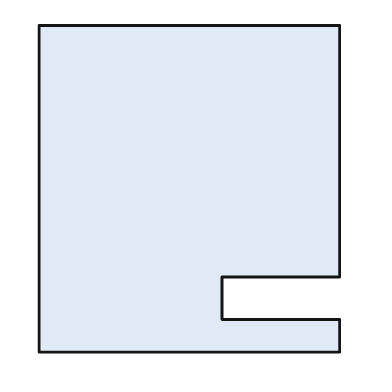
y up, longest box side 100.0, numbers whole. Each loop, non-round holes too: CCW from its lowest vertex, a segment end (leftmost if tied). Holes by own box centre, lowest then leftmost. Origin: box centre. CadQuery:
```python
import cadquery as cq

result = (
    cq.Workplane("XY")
    .moveTo(-46.0, -50.0)
    .lineTo(46.0, -50.0)
    .lineTo(46.0, -40.0)
    .lineTo(10.0, -40.0)
    .lineTo(10.0, -27.0)
    .lineTo(46.0, -27.0)
    .lineTo(46.0, 50.0)
    .lineTo(-46.0, 50.0)
    .close()
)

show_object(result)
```